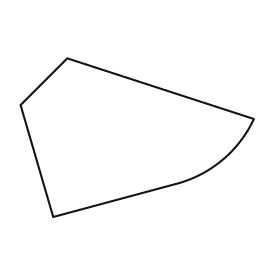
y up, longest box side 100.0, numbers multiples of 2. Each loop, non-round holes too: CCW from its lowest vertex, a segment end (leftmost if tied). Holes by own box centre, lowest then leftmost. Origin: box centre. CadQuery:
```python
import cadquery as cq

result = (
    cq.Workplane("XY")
    .moveTo(-36.0, -34.0)
    .lineTo(16.0, -20.0)
    .threePointArc((36.0, -10.0), (50.0, 8.0))
    .lineTo(-30.0, 34.0)
    .lineTo(-50.0, 14.0)
    .close()
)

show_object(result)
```